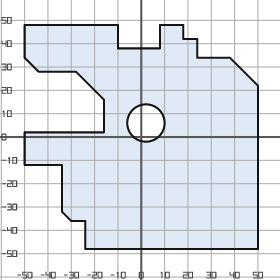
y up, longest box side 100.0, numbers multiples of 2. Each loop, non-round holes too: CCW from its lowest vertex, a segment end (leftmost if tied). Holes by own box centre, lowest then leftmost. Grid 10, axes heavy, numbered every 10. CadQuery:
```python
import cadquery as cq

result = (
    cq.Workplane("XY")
    .moveTo(-24.0, -48.0)
    .lineTo(50.0, -48.0)
    .lineTo(50.0, 22.0)
    .lineTo(38.0, 34.0)
    .lineTo(24.0, 34.0)
    .lineTo(24.0, 42.0)
    .lineTo(18.0, 42.0)
    .lineTo(18.0, 48.0)
    .lineTo(8.0, 48.0)
    .lineTo(8.0, 38.0)
    .lineTo(-10.0, 38.0)
    .lineTo(-10.0, 48.0)
    .lineTo(-50.0, 48.0)
    .lineTo(-50.0, 34.0)
    .lineTo(-44.0, 28.0)
    .lineTo(-28.0, 28.0)
    .lineTo(-16.0, 16.0)
    .lineTo(-16.0, 2.0)
    .lineTo(-50.0, 2.0)
    .lineTo(-50.0, -12.0)
    .lineTo(-34.0, -12.0)
    .lineTo(-34.0, -32.0)
    .lineTo(-30.0, -36.0)
    .lineTo(-24.0, -36.0)
    .close()
    .moveTo(2.0, 6.0)
    .circle(8.0)
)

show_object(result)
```